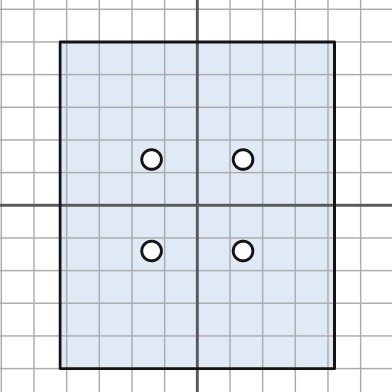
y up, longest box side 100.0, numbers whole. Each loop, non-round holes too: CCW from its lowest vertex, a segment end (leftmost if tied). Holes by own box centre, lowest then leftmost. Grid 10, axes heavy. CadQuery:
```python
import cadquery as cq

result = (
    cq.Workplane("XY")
    .moveTo(-42.0, -50.0)
    .lineTo(42.0, -50.0)
    .lineTo(42.0, 50.0)
    .lineTo(-42.0, 50.0)
    .close()
    .moveTo(-14.0, -14.0)
    .circle(3.0)
    .moveTo(14.0, -14.0)
    .circle(3.0)
    .moveTo(-14.0, 14.0)
    .circle(3.0)
    .moveTo(14.0, 14.0)
    .circle(3.0)
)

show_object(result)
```